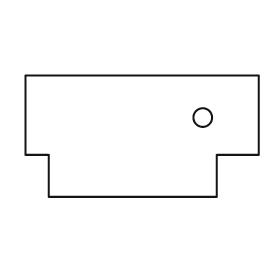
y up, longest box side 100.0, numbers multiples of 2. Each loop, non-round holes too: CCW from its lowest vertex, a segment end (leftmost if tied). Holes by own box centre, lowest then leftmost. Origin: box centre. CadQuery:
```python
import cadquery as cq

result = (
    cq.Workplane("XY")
    .moveTo(-40.0, -26.0)
    .lineTo(32.0, -26.0)
    .lineTo(32.0, -8.0)
    .lineTo(50.0, -8.0)
    .lineTo(50.0, 26.0)
    .lineTo(-50.0, 26.0)
    .lineTo(-50.0, -8.0)
    .lineTo(-40.0, -8.0)
    .close()
    .moveTo(26.0, 8.0)
    .circle(4.0)
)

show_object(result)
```